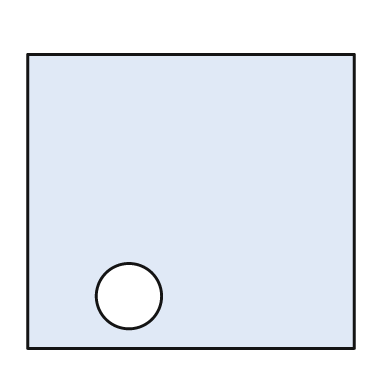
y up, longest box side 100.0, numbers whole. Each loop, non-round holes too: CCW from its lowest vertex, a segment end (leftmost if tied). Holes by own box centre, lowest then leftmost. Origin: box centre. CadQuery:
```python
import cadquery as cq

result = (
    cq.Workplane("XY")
    .moveTo(-50.0, -45.0)
    .lineTo(50.0, -45.0)
    .lineTo(50.0, 45.0)
    .lineTo(-50.0, 45.0)
    .close()
    .moveTo(-19.0, -29.0)
    .circle(10.0)
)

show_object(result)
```